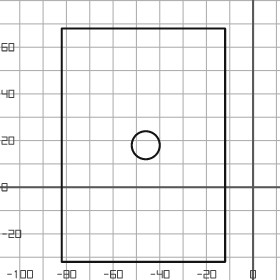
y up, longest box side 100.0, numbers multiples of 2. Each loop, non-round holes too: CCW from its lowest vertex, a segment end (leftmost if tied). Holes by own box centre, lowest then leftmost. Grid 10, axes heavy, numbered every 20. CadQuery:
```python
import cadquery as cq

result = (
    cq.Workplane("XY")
    .moveTo(-82.0, -32.0)
    .lineTo(-12.0, -32.0)
    .lineTo(-12.0, 68.0)
    .lineTo(-82.0, 68.0)
    .close()
    .moveTo(-46.0, 18.0)
    .circle(6.0)
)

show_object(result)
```